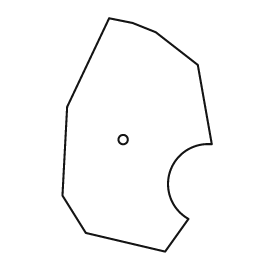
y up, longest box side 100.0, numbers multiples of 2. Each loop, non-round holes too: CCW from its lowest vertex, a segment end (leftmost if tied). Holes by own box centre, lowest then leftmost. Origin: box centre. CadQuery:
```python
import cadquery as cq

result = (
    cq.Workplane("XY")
    .moveTo(12.0, -50.0)
    .lineTo(22.0, -36.0)
    .threePointArc((14.0, -16.0), (32.0, -4.0))
    .lineTo(26.0, 30.0)
    .lineTo(8.0, 44.0)
    .lineTo(-2.0, 48.0)
    .lineTo(-12.0, 50.0)
    .lineTo(-30.0, 12.0)
    .lineTo(-32.0, -26.0)
    .lineTo(-22.0, -42.0)
    .close()
    .moveTo(-6.0, -2.0)
    .circle(2.0)
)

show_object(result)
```